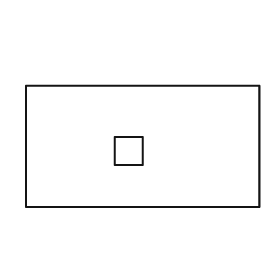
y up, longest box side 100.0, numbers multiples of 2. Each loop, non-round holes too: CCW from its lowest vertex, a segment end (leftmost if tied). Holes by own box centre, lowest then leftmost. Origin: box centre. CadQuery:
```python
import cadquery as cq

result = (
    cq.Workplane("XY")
    .moveTo(-50.0, -26.0)
    .lineTo(50.0, -26.0)
    .lineTo(50.0, 26.0)
    .lineTo(-50.0, 26.0)
    .close()
    .moveTo(-12.0, -8.0)
    .lineTo(0.0, -8.0)
    .lineTo(0.0, 4.0)
    .lineTo(-12.0, 4.0)
    .close()
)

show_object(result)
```